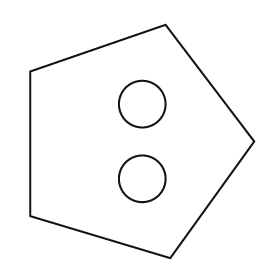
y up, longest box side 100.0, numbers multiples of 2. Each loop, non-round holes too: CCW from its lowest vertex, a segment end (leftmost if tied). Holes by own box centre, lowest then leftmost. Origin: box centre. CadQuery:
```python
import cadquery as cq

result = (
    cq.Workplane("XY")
    .moveTo(12.0, -50.0)
    .lineTo(48.0, 0.0)
    .lineTo(10.0, 50.0)
    .lineTo(-48.0, 30.0)
    .lineTo(-48.0, -32.0)
    .close()
    .moveTo(0.0, -16.0)
    .circle(10.0)
    .moveTo(0.0, 16.0)
    .circle(10.0)
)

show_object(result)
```